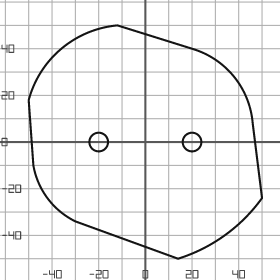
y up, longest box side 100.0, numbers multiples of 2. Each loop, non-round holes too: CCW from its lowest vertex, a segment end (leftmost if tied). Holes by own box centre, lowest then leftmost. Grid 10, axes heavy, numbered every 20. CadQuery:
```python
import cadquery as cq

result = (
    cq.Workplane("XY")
    .moveTo(14.0, -50.0)
    .threePointArc((34.0, -40.0), (50.0, -24.0))
    .lineTo(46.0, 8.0)
    .threePointArc((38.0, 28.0), (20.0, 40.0))
    .lineTo(-12.0, 50.0)
    .threePointArc((-36.0, 40.0), (-50.0, 18.0))
    .lineTo(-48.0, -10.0)
    .threePointArc((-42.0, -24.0), (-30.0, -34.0))
    .close()
    .moveTo(-20.0, 0.0)
    .circle(4.0)
    .moveTo(20.0, 0.0)
    .circle(4.0)
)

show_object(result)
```